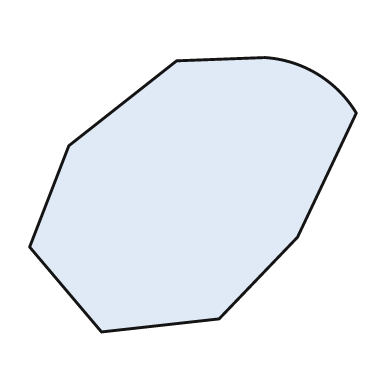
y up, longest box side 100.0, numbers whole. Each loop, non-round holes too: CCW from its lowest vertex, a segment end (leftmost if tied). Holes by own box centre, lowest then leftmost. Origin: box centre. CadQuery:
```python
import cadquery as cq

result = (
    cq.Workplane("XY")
    .moveTo(-28.0, -42.0)
    .lineTo(8.0, -38.0)
    .lineTo(32.0, -13.0)
    .lineTo(50.0, 25.0)
    .threePointArc((38.0, 37.0), (22.0, 42.0))
    .lineTo(-5.0, 41.0)
    .lineTo(-38.0, 15.0)
    .lineTo(-50.0, -16.0)
    .close()
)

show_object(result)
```